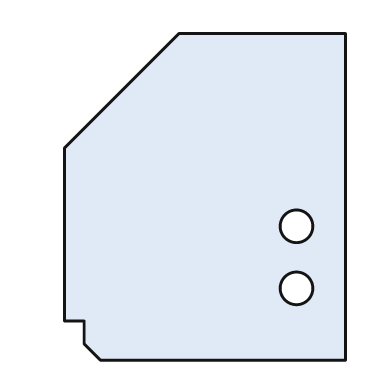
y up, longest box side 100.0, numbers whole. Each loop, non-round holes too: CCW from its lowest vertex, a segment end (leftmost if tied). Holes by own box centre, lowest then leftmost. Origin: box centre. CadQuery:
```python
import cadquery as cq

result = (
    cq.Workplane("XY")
    .moveTo(-32.0, -50.0)
    .lineTo(43.0, -50.0)
    .lineTo(43.0, 50.0)
    .lineTo(-8.0, 50.0)
    .lineTo(-43.0, 15.0)
    .lineTo(-43.0, -38.0)
    .lineTo(-37.0, -38.0)
    .lineTo(-37.0, -45.0)
    .close()
    .moveTo(28.0, -28.0)
    .circle(5.0)
    .moveTo(28.0, -9.0)
    .circle(5.0)
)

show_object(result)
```